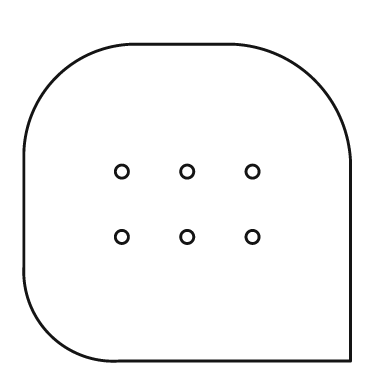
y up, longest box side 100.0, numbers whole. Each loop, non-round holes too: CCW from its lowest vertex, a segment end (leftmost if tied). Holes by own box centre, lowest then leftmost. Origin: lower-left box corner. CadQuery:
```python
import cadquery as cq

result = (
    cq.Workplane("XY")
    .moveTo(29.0, 0.0)
    .lineTo(100.0, 0.0)
    .lineTo(100.0, 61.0)
    .threePointArc((89.0, 86.0), (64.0, 97.0))
    .lineTo(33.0, 97.0)
    .threePointArc((10.0, 87.0), (0.0, 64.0))
    .lineTo(0.0, 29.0)
    .threePointArc((8.0, 8.0), (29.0, 0.0))
    .close()
    .moveTo(30.0, 38.0)
    .circle(2.0)
    .moveTo(50.0, 38.0)
    .circle(2.0)
    .moveTo(70.0, 38.0)
    .circle(2.0)
    .moveTo(30.0, 58.0)
    .circle(2.0)
    .moveTo(50.0, 58.0)
    .circle(2.0)
    .moveTo(70.0, 58.0)
    .circle(2.0)
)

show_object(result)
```